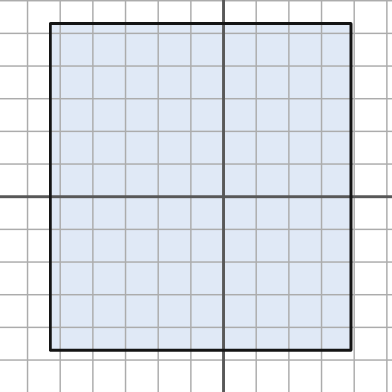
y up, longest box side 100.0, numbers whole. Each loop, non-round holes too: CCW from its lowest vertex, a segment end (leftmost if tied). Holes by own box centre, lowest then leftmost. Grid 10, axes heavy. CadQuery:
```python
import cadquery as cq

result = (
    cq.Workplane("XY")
    .moveTo(-53.0, -47.0)
    .lineTo(39.0, -47.0)
    .lineTo(39.0, 53.0)
    .lineTo(-53.0, 53.0)
    .close()
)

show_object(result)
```